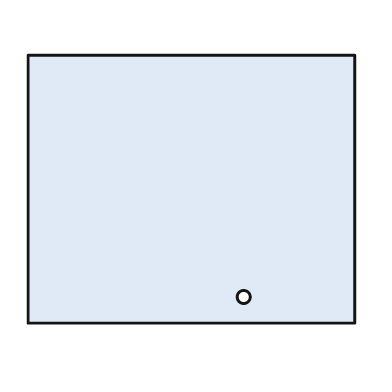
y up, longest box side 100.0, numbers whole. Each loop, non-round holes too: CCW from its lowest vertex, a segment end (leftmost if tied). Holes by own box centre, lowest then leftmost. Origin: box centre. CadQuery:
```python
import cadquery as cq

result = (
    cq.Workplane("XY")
    .moveTo(-50.0, -41.0)
    .lineTo(50.0, -41.0)
    .lineTo(50.0, 41.0)
    .lineTo(-50.0, 41.0)
    .close()
    .moveTo(16.0, -33.0)
    .circle(2.0)
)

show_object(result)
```